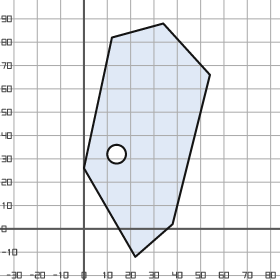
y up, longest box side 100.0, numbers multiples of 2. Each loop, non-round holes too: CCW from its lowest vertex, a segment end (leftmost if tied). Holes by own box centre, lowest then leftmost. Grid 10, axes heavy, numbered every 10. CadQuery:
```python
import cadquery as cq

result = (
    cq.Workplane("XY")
    .moveTo(22.0, -12.0)
    .lineTo(38.0, 2.0)
    .lineTo(54.0, 66.0)
    .lineTo(34.0, 88.0)
    .lineTo(12.0, 82.0)
    .lineTo(0.0, 26.0)
    .close()
    .moveTo(14.0, 32.0)
    .circle(4.0)
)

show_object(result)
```